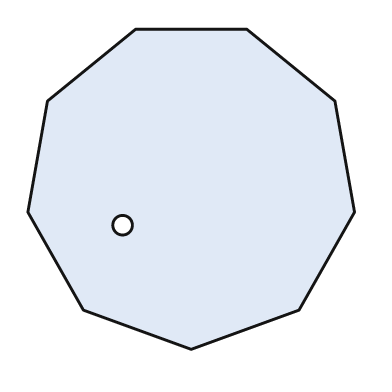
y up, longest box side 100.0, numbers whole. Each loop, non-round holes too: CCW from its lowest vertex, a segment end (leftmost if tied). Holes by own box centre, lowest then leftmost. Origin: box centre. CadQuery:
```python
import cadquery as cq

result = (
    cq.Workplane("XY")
    .moveTo(0.0, -49.0)
    .lineTo(33.0, -37.0)
    .lineTo(50.0, -7.0)
    .lineTo(44.0, 27.0)
    .lineTo(17.0, 49.0)
    .lineTo(-17.0, 49.0)
    .lineTo(-44.0, 27.0)
    .lineTo(-50.0, -7.0)
    .lineTo(-33.0, -37.0)
    .close()
    .moveTo(-21.0, -11.0)
    .circle(3.0)
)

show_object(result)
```